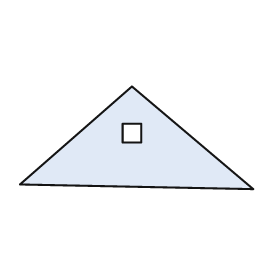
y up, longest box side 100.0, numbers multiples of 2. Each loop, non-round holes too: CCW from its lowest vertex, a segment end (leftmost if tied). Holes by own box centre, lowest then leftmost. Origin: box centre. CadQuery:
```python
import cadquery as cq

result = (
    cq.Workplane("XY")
    .moveTo(50.0, -22.0)
    .lineTo(-2.0, 22.0)
    .lineTo(-50.0, -20.0)
    .close()
    .moveTo(-6.0, -2.0)
    .lineTo(2.0, -2.0)
    .lineTo(2.0, 6.0)
    .lineTo(-6.0, 6.0)
    .close()
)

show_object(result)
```